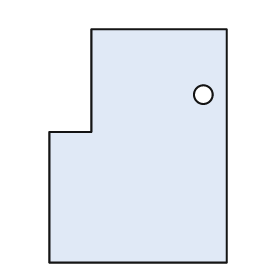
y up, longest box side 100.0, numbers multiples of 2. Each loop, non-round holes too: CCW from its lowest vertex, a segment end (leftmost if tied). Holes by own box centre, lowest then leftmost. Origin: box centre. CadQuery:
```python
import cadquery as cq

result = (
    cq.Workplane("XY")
    .moveTo(-38.0, -50.0)
    .lineTo(38.0, -50.0)
    .lineTo(38.0, 50.0)
    .lineTo(-20.0, 50.0)
    .lineTo(-20.0, 6.0)
    .lineTo(-38.0, 6.0)
    .close()
    .moveTo(28.0, 22.0)
    .circle(4.0)
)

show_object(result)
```